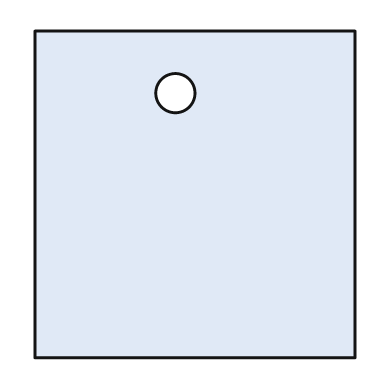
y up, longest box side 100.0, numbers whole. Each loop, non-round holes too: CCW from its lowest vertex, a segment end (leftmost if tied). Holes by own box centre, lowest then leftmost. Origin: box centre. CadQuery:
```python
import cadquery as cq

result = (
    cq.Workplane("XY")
    .moveTo(-49.0, -50.0)
    .lineTo(49.0, -50.0)
    .lineTo(49.0, 50.0)
    .lineTo(-49.0, 50.0)
    .close()
    .moveTo(-6.0, 31.0)
    .circle(6.0)
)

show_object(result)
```